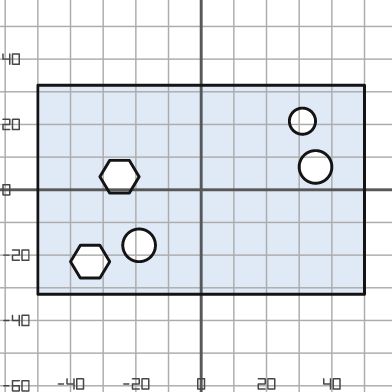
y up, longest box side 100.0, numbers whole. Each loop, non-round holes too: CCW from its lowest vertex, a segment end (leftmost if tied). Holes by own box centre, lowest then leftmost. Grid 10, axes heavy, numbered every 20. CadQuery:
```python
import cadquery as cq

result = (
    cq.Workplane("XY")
    .moveTo(-50.0, -32.0)
    .lineTo(50.0, -32.0)
    .lineTo(50.0, 32.0)
    .lineTo(-50.0, 32.0)
    .close()
    .moveTo(-37.0, -27.0)
    .lineTo(-31.0, -27.0)
    .lineTo(-28.0, -22.0)
    .lineTo(-31.0, -17.0)
    .lineTo(-37.0, -17.0)
    .lineTo(-40.0, -22.0)
    .close()
    .moveTo(-19.0, -17.0)
    .circle(5.0)
    .moveTo(-28.0, -1.0)
    .lineTo(-22.0, -1.0)
    .lineTo(-19.0, 4.0)
    .lineTo(-22.0, 9.0)
    .lineTo(-28.0, 9.0)
    .lineTo(-31.0, 4.0)
    .close()
    .moveTo(35.0, 7.0)
    .circle(5.0)
    .moveTo(31.0, 21.0)
    .circle(4.0)
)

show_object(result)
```